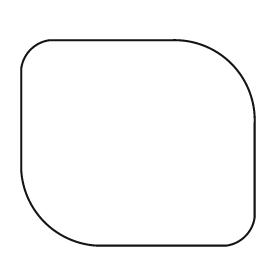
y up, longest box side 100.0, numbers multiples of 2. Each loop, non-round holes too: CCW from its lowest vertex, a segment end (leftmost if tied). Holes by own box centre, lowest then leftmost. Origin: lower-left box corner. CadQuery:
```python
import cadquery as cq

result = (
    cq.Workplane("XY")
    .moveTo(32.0, 0.0)
    .lineTo(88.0, 0.0)
    .threePointArc((96.0, 4.0), (100.0, 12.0))
    .lineTo(100.0, 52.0)
    .threePointArc((90.0, 78.0), (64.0, 88.0))
    .lineTo(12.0, 88.0)
    .threePointArc((4.0, 84.0), (0.0, 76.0))
    .lineTo(0.0, 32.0)
    .threePointArc((10.0, 10.0), (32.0, 0.0))
    .close()
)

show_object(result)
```